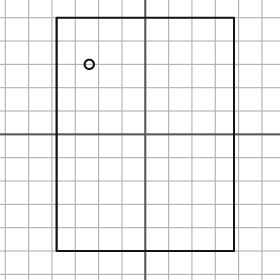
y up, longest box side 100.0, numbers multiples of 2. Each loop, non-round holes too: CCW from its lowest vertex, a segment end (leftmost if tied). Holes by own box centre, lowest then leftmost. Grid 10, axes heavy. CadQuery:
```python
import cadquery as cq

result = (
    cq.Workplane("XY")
    .moveTo(-38.0, -50.0)
    .lineTo(38.0, -50.0)
    .lineTo(38.0, 50.0)
    .lineTo(-38.0, 50.0)
    .close()
    .moveTo(-24.0, 30.0)
    .circle(2.0)
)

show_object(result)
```